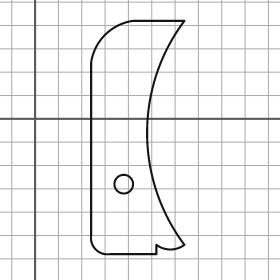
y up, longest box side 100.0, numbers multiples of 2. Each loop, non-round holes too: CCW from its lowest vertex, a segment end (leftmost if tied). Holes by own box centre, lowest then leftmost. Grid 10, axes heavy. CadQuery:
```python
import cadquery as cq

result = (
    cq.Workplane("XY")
    .moveTo(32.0, -58.0)
    .lineTo(52.0, -58.0)
    .lineTo(52.0, -54.0)
    .threePointArc((58.0, -56.0), (64.0, -54.0))
    .threePointArc((48.0, -6.0), (64.0, 42.0))
    .lineTo(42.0, 42.0)
    .threePointArc((30.0, 36.0), (24.0, 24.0))
    .lineTo(24.0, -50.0)
    .threePointArc((26.0, -56.0), (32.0, -58.0))
    .close()
    .moveTo(38.0, -28.0)
    .circle(4.0)
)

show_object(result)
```